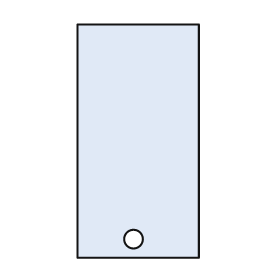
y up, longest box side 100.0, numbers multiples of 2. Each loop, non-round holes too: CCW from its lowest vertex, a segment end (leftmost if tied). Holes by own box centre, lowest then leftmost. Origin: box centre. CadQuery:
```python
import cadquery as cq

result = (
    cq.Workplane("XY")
    .moveTo(-26.0, -50.0)
    .lineTo(26.0, -50.0)
    .lineTo(26.0, 50.0)
    .lineTo(-26.0, 50.0)
    .close()
    .moveTo(-2.0, -42.0)
    .circle(4.0)
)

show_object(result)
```